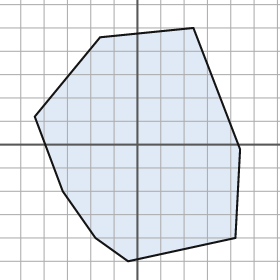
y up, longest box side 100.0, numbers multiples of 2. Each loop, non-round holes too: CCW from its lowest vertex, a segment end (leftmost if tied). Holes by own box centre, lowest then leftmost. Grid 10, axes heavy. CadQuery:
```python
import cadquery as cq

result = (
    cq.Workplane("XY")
    .moveTo(-4.0, -50.0)
    .lineTo(42.0, -40.0)
    .lineTo(44.0, -2.0)
    .lineTo(24.0, 50.0)
    .lineTo(-16.0, 46.0)
    .lineTo(-44.0, 12.0)
    .lineTo(-32.0, -20.0)
    .lineTo(-18.0, -40.0)
    .close()
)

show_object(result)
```